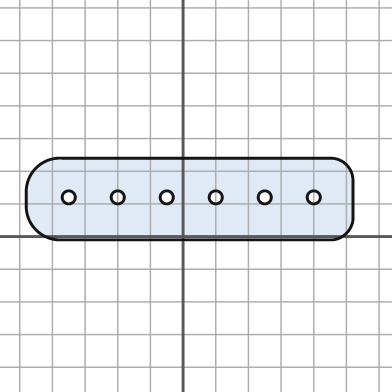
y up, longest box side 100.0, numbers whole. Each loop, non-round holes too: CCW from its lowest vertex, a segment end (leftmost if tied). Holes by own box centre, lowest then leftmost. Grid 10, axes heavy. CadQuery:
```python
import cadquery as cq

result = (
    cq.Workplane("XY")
    .moveTo(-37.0, -1.0)
    .lineTo(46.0, -1.0)
    .threePointArc((50.0, 1.0), (52.0, 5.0))
    .lineTo(52.0, 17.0)
    .threePointArc((50.0, 22.0), (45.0, 24.0))
    .lineTo(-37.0, 24.0)
    .threePointArc((-45.0, 21.0), (-48.0, 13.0))
    .lineTo(-48.0, 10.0)
    .threePointArc((-45.0, 2.0), (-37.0, -1.0))
    .close()
    .moveTo(-35.0, 12.0)
    .circle(2.0)
    .moveTo(-20.0, 12.0)
    .circle(2.0)
    .moveTo(-5.0, 12.0)
    .circle(2.0)
    .moveTo(10.0, 12.0)
    .circle(2.0)
    .moveTo(25.0, 12.0)
    .circle(2.0)
    .moveTo(40.0, 12.0)
    .circle(2.0)
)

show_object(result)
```